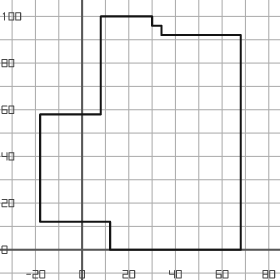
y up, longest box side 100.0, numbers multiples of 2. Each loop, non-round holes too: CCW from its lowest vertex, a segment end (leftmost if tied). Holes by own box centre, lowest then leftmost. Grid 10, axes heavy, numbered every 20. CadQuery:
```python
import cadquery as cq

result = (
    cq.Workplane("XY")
    .moveTo(12.0, 0.0)
    .lineTo(68.0, 0.0)
    .lineTo(68.0, 92.0)
    .lineTo(34.0, 92.0)
    .lineTo(34.0, 96.0)
    .lineTo(30.0, 96.0)
    .lineTo(30.0, 100.0)
    .lineTo(8.0, 100.0)
    .lineTo(8.0, 58.0)
    .lineTo(-18.0, 58.0)
    .lineTo(-18.0, 12.0)
    .lineTo(12.0, 12.0)
    .close()
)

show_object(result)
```